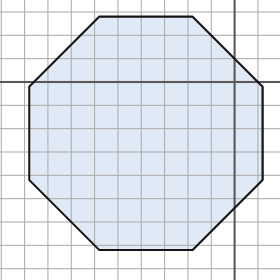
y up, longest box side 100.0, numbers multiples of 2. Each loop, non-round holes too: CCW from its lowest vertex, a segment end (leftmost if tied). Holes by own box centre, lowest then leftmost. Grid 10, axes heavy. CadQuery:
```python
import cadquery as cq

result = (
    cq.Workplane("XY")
    .moveTo(-58.0, -72.0)
    .lineTo(-18.0, -72.0)
    .lineTo(12.0, -42.0)
    .lineTo(12.0, -2.0)
    .lineTo(-18.0, 28.0)
    .lineTo(-58.0, 28.0)
    .lineTo(-88.0, -2.0)
    .lineTo(-88.0, -42.0)
    .close()
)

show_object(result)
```